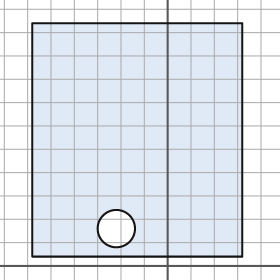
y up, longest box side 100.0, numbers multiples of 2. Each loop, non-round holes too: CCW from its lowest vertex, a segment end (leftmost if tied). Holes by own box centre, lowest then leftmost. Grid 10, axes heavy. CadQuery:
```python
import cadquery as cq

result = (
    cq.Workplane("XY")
    .moveTo(-58.0, 4.0)
    .lineTo(32.0, 4.0)
    .lineTo(32.0, 104.0)
    .lineTo(-58.0, 104.0)
    .close()
    .moveTo(-22.0, 16.0)
    .circle(8.0)
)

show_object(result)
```